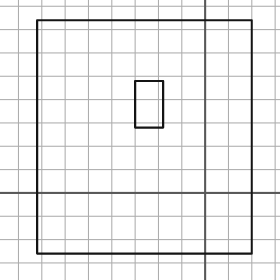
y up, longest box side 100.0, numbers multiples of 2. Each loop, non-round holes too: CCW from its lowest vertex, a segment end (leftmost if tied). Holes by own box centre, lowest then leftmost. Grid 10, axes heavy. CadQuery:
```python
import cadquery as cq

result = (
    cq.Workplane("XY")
    .moveTo(-72.0, -26.0)
    .lineTo(20.0, -26.0)
    .lineTo(20.0, 74.0)
    .lineTo(-72.0, 74.0)
    .close()
    .moveTo(-30.0, 28.0)
    .lineTo(-18.0, 28.0)
    .lineTo(-18.0, 48.0)
    .lineTo(-30.0, 48.0)
    .close()
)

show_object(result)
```